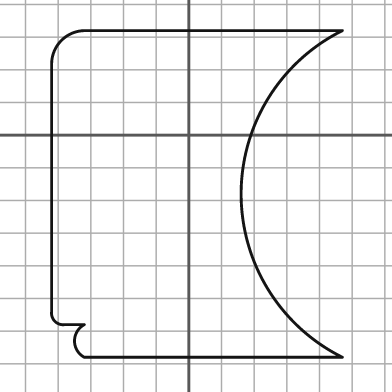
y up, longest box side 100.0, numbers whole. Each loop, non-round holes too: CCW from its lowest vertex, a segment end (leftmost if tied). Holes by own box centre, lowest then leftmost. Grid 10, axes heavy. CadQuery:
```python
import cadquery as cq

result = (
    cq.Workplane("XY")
    .moveTo(-32.0, -68.0)
    .lineTo(47.0, -68.0)
    .threePointArc((16.0, -18.0), (47.0, 32.0))
    .lineTo(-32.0, 32.0)
    .threePointArc((-39.0, 29.0), (-42.0, 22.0))
    .lineTo(-42.0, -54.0)
    .threePointArc((-41.0, -57.0), (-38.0, -58.0))
    .lineTo(-32.0, -58.0)
    .threePointArc((-35.0, -63.0), (-32.0, -68.0))
    .close()
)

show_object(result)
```